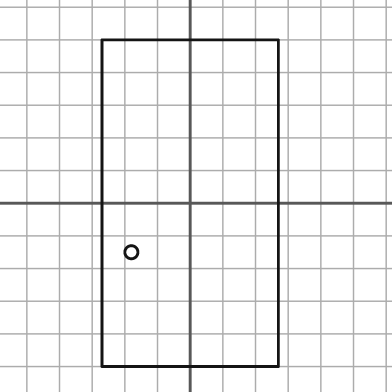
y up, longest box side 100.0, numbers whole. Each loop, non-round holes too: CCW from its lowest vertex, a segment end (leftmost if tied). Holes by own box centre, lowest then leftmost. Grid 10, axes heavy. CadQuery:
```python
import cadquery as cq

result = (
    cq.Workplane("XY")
    .moveTo(-27.0, -50.0)
    .lineTo(27.0, -50.0)
    .lineTo(27.0, 50.0)
    .lineTo(-27.0, 50.0)
    .close()
    .moveTo(-18.0, -15.0)
    .circle(2.0)
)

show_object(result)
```